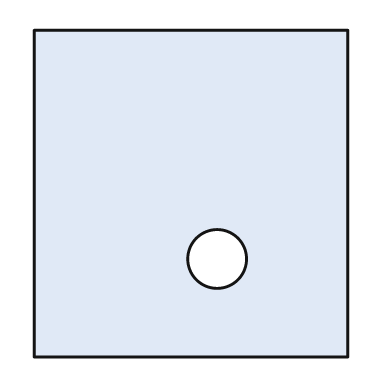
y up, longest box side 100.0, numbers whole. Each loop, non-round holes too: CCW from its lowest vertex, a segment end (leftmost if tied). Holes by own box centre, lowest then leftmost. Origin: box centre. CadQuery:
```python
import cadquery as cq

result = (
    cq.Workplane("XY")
    .moveTo(-48.0, -50.0)
    .lineTo(48.0, -50.0)
    .lineTo(48.0, 50.0)
    .lineTo(-48.0, 50.0)
    .close()
    .moveTo(8.0, -20.0)
    .circle(9.0)
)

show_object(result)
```